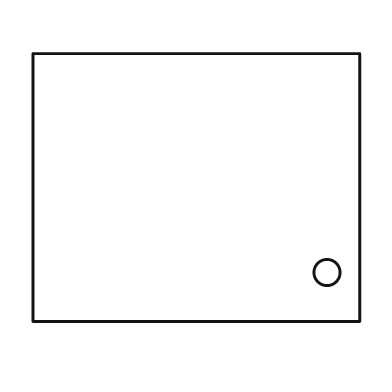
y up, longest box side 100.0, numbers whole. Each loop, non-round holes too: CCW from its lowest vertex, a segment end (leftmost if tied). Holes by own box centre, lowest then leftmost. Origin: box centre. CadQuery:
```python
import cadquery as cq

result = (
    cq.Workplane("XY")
    .moveTo(-50.0, -41.0)
    .lineTo(50.0, -41.0)
    .lineTo(50.0, 41.0)
    .lineTo(-50.0, 41.0)
    .close()
    .moveTo(40.0, -26.0)
    .circle(4.0)
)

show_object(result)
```